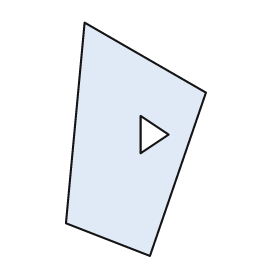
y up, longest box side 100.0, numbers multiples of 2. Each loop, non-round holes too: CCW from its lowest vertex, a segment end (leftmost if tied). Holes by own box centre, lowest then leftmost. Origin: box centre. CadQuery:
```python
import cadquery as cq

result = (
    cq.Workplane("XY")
    .moveTo(6.0, -50.0)
    .lineTo(30.0, 20.0)
    .lineTo(-22.0, 50.0)
    .lineTo(-30.0, -36.0)
    .close()
    .moveTo(2.0, -6.0)
    .lineTo(14.0, 2.0)
    .lineTo(2.0, 10.0)
    .close()
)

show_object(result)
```